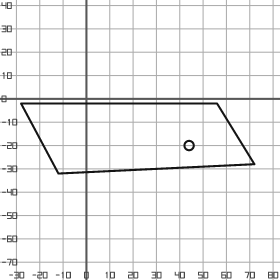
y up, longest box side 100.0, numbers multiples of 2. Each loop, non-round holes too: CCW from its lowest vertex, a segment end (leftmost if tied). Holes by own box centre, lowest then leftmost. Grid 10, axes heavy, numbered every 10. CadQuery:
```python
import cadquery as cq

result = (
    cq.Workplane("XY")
    .moveTo(-12.0, -32.0)
    .lineTo(72.0, -28.0)
    .lineTo(56.0, -2.0)
    .lineTo(-28.0, -2.0)
    .close()
    .moveTo(44.0, -20.0)
    .circle(2.0)
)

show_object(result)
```